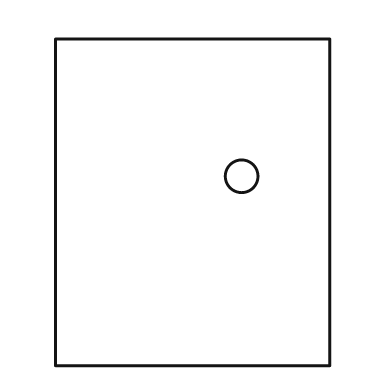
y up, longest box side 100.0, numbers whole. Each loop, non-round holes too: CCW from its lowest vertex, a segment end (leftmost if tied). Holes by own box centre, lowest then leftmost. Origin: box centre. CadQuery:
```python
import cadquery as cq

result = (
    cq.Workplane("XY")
    .moveTo(-42.0, -50.0)
    .lineTo(42.0, -50.0)
    .lineTo(42.0, 50.0)
    .lineTo(-42.0, 50.0)
    .close()
    .moveTo(15.0, 8.0)
    .circle(5.0)
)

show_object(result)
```